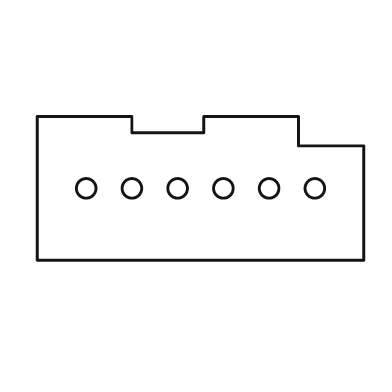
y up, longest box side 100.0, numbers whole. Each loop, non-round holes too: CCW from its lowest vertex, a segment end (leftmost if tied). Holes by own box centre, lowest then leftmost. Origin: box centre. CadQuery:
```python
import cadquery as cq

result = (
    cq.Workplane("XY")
    .moveTo(-50.0, -22.0)
    .lineTo(50.0, -22.0)
    .lineTo(50.0, 13.0)
    .lineTo(30.0, 13.0)
    .lineTo(30.0, 22.0)
    .lineTo(1.0, 22.0)
    .lineTo(1.0, 17.0)
    .lineTo(-21.0, 17.0)
    .lineTo(-21.0, 22.0)
    .lineTo(-50.0, 22.0)
    .close()
    .moveTo(-35.0, 0.0)
    .circle(3.0)
    .moveTo(-21.0, 0.0)
    .circle(3.0)
    .moveTo(-7.0, 0.0)
    .circle(3.0)
    .moveTo(7.0, 0.0)
    .circle(3.0)
    .moveTo(21.0, 0.0)
    .circle(3.0)
    .moveTo(35.0, 0.0)
    .circle(3.0)
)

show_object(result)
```